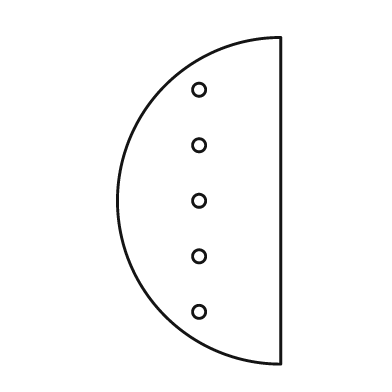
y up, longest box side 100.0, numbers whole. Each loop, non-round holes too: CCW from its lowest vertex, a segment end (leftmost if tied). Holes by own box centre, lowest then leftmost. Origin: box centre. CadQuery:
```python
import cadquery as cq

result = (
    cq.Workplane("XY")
    .moveTo(25.0, -50.0)
    .lineTo(25.0, 50.0)
    .threePointArc((-25.0, 0.0), (25.0, -50.0))
    .close()
    .moveTo(0.0, -34.0)
    .circle(2.0)
    .moveTo(0.0, -17.0)
    .circle(2.0)
    .moveTo(0.0, 0.0)
    .circle(2.0)
    .moveTo(0.0, 17.0)
    .circle(2.0)
    .moveTo(0.0, 34.0)
    .circle(2.0)
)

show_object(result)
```